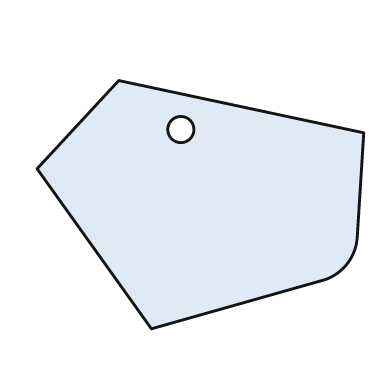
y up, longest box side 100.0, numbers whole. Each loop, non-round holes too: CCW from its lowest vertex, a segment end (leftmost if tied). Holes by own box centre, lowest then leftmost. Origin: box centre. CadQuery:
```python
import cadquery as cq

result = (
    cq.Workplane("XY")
    .moveTo(-15.0, -38.0)
    .lineTo(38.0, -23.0)
    .threePointArc((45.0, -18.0), (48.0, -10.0))
    .lineTo(50.0, 22.0)
    .lineTo(-25.0, 38.0)
    .lineTo(-50.0, 11.0)
    .close()
    .moveTo(-6.0, 23.0)
    .circle(4.0)
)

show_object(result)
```